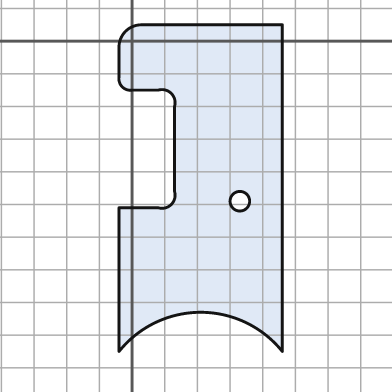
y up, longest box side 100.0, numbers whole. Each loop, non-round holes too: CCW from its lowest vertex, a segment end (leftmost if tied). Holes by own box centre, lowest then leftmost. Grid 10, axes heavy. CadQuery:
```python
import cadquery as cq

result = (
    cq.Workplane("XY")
    .moveTo(-4.0, -95.0)
    .threePointArc((21.0, -83.0), (46.0, -95.0))
    .lineTo(46.0, 5.0)
    .lineTo(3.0, 5.0)
    .threePointArc((-2.0, 3.0), (-4.0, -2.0))
    .lineTo(-4.0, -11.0)
    .threePointArc((-3.0, -14.0), (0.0, -15.0))
    .lineTo(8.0, -15.0)
    .threePointArc((12.0, -16.0), (13.0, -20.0))
    .lineTo(13.0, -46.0)
    .threePointArc((12.0, -50.0), (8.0, -51.0))
    .lineTo(-4.0, -51.0)
    .close()
    .moveTo(33.0, -49.0)
    .circle(3.0)
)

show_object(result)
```